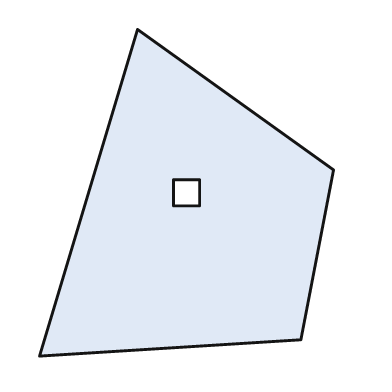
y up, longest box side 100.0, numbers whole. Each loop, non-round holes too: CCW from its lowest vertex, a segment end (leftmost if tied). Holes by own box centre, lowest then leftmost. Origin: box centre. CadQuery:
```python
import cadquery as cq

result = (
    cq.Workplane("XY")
    .moveTo(-45.0, -50.0)
    .lineTo(35.0, -45.0)
    .lineTo(45.0, 7.0)
    .lineTo(-15.0, 50.0)
    .close()
    .moveTo(-4.0, -4.0)
    .lineTo(4.0, -4.0)
    .lineTo(4.0, 4.0)
    .lineTo(-4.0, 4.0)
    .close()
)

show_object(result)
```